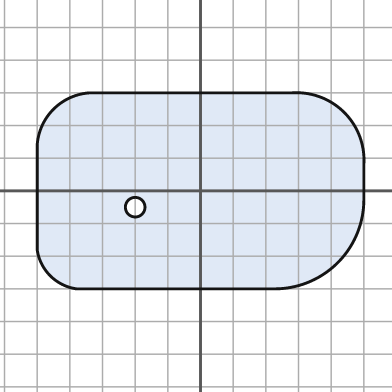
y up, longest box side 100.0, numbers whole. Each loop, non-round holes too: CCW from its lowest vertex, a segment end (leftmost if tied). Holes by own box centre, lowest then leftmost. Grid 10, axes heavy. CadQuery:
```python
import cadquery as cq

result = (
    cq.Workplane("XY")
    .moveTo(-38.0, -30.0)
    .lineTo(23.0, -30.0)
    .threePointArc((42.0, -22.0), (50.0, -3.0))
    .lineTo(50.0, 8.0)
    .threePointArc((44.0, 24.0), (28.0, 30.0))
    .lineTo(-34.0, 30.0)
    .threePointArc((-45.0, 25.0), (-50.0, 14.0))
    .lineTo(-50.0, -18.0)
    .threePointArc((-46.0, -26.0), (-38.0, -30.0))
    .close()
    .moveTo(-20.0, -5.0)
    .circle(3.0)
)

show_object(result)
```